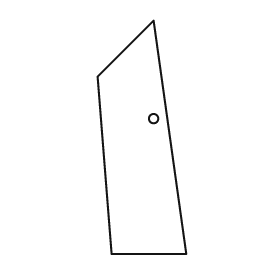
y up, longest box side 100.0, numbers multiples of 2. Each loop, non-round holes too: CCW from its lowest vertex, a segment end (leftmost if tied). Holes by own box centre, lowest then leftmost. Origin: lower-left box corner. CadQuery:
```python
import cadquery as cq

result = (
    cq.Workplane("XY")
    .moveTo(6.0, 0.0)
    .lineTo(38.0, 0.0)
    .lineTo(24.0, 100.0)
    .lineTo(0.0, 76.0)
    .close()
    .moveTo(24.0, 58.0)
    .circle(2.0)
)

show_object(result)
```